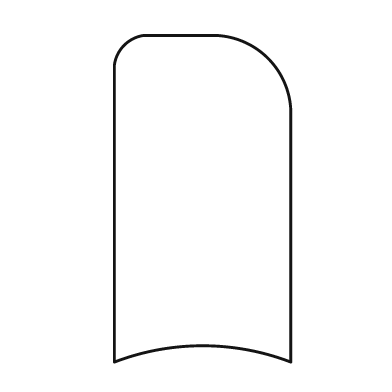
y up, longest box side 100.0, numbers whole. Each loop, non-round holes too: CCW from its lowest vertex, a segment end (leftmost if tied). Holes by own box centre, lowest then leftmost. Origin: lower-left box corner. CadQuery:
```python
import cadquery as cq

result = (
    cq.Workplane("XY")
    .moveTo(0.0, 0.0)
    .threePointArc((27.0, 5.0), (54.0, 0.0))
    .lineTo(54.0, 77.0)
    .threePointArc((47.0, 93.0), (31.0, 100.0))
    .lineTo(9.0, 100.0)
    .threePointArc((3.0, 97.0), (0.0, 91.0))
    .close()
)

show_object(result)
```